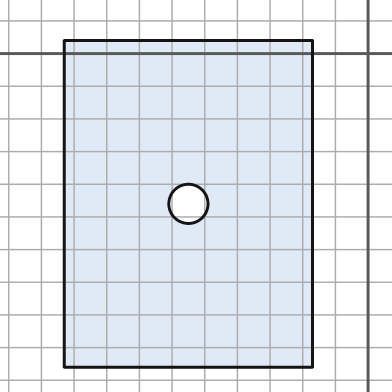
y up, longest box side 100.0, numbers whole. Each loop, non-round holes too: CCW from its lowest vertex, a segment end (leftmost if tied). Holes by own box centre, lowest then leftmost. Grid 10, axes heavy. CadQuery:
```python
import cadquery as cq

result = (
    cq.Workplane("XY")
    .moveTo(-93.0, -96.0)
    .lineTo(-17.0, -96.0)
    .lineTo(-17.0, 4.0)
    .lineTo(-93.0, 4.0)
    .close()
    .moveTo(-55.0, -46.0)
    .circle(6.0)
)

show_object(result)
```